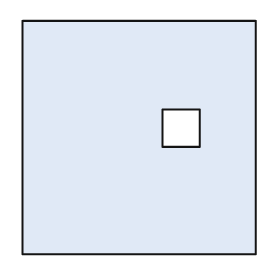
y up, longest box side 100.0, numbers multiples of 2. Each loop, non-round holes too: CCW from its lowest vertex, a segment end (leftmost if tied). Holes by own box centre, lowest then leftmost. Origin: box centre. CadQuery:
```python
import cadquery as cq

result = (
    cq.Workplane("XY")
    .moveTo(-50.0, -50.0)
    .lineTo(50.0, -50.0)
    .lineTo(50.0, 50.0)
    .lineTo(-50.0, 50.0)
    .close()
    .moveTo(10.0, -4.0)
    .lineTo(26.0, -4.0)
    .lineTo(26.0, 12.0)
    .lineTo(10.0, 12.0)
    .close()
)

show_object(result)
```